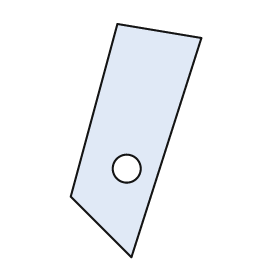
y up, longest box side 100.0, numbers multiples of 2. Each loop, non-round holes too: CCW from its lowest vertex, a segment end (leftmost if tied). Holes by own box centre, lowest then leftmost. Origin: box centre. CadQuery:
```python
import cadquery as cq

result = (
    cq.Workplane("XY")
    .moveTo(-2.0, -50.0)
    .lineTo(28.0, 44.0)
    .lineTo(-8.0, 50.0)
    .lineTo(-28.0, -24.0)
    .close()
    .moveTo(-4.0, -12.0)
    .circle(6.0)
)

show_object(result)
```